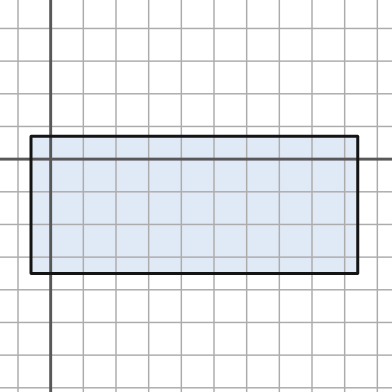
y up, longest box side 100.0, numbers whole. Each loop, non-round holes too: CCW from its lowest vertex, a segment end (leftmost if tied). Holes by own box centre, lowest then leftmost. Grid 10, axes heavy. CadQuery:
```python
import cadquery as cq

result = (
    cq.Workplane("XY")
    .moveTo(-6.0, -35.0)
    .lineTo(94.0, -35.0)
    .lineTo(94.0, 7.0)
    .lineTo(-6.0, 7.0)
    .close()
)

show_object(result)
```